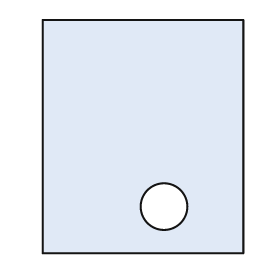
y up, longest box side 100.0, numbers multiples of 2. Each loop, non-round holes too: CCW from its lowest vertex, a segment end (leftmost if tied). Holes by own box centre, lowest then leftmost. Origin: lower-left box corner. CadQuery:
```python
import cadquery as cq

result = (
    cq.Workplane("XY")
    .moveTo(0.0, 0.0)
    .lineTo(86.0, 0.0)
    .lineTo(86.0, 100.0)
    .lineTo(0.0, 100.0)
    .close()
    .moveTo(52.0, 20.0)
    .circle(10.0)
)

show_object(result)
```